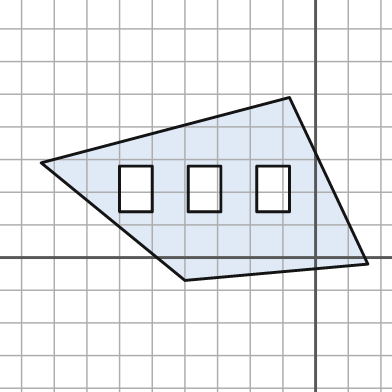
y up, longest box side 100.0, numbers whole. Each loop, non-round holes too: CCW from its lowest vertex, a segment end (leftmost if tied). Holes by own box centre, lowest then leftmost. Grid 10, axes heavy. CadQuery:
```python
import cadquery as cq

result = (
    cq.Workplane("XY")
    .moveTo(-40.0, -7.0)
    .lineTo(16.0, -2.0)
    .lineTo(-8.0, 49.0)
    .lineTo(-84.0, 29.0)
    .close()
    .moveTo(-60.0, 14.0)
    .lineTo(-50.0, 14.0)
    .lineTo(-50.0, 28.0)
    .lineTo(-60.0, 28.0)
    .close()
    .moveTo(-39.0, 14.0)
    .lineTo(-29.0, 14.0)
    .lineTo(-29.0, 28.0)
    .lineTo(-39.0, 28.0)
    .close()
    .moveTo(-18.0, 14.0)
    .lineTo(-8.0, 14.0)
    .lineTo(-8.0, 28.0)
    .lineTo(-18.0, 28.0)
    .close()
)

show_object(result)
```